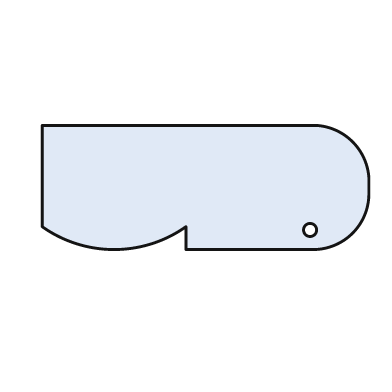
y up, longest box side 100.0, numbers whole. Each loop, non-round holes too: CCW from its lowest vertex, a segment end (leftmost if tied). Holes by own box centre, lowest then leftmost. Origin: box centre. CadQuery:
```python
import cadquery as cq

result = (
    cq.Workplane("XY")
    .moveTo(-6.0, -19.0)
    .lineTo(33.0, -19.0)
    .threePointArc((45.0, -14.0), (50.0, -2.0))
    .lineTo(50.0, 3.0)
    .threePointArc((45.0, 14.0), (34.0, 19.0))
    .lineTo(-50.0, 19.0)
    .lineTo(-50.0, -12.0)
    .threePointArc((-28.0, -19.0), (-6.0, -12.0))
    .close()
    .moveTo(32.0, -13.0)
    .circle(2.0)
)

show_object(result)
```